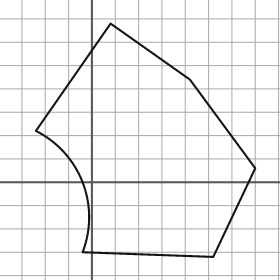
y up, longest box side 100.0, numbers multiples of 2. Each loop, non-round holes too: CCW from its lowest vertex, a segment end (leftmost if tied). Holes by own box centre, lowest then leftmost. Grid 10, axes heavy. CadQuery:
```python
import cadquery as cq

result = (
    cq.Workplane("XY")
    .moveTo(52.0, -32.0)
    .lineTo(70.0, 6.0)
    .lineTo(42.0, 44.0)
    .lineTo(8.0, 68.0)
    .lineTo(-24.0, 22.0)
    .threePointArc((-4.0, 0.0), (-4.0, -30.0))
    .close()
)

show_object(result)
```